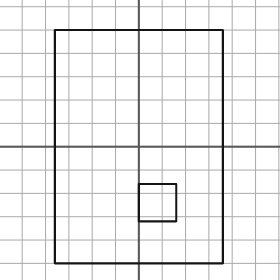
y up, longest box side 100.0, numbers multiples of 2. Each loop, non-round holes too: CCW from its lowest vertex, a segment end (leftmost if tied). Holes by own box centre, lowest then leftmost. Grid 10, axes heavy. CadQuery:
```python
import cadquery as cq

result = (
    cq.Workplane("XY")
    .moveTo(-36.0, -50.0)
    .lineTo(36.0, -50.0)
    .lineTo(36.0, 50.0)
    .lineTo(-36.0, 50.0)
    .close()
    .moveTo(0.0, -32.0)
    .lineTo(16.0, -32.0)
    .lineTo(16.0, -16.0)
    .lineTo(0.0, -16.0)
    .close()
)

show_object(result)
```